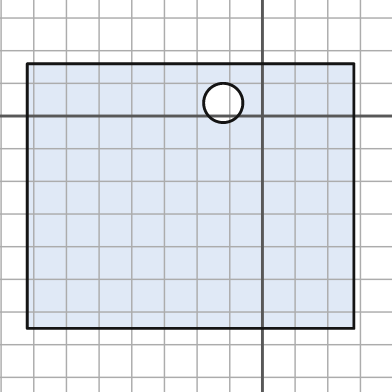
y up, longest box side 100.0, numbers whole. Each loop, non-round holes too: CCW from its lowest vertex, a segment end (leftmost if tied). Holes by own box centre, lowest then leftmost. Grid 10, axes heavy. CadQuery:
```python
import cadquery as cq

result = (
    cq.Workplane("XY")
    .moveTo(-72.0, -65.0)
    .lineTo(28.0, -65.0)
    .lineTo(28.0, 16.0)
    .lineTo(-72.0, 16.0)
    .close()
    .moveTo(-12.0, 4.0)
    .circle(6.0)
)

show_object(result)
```